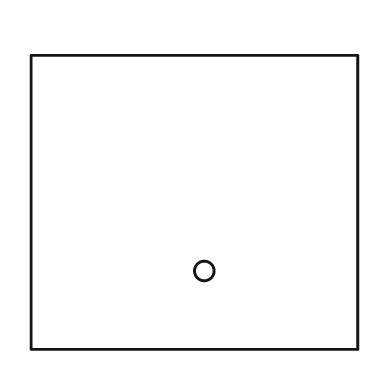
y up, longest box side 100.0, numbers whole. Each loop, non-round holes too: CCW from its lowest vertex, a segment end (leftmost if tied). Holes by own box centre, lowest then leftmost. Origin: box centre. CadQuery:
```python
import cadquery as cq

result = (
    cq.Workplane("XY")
    .moveTo(-50.0, -45.0)
    .lineTo(50.0, -45.0)
    .lineTo(50.0, 45.0)
    .lineTo(-50.0, 45.0)
    .close()
    .moveTo(3.0, -21.0)
    .circle(3.0)
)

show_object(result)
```